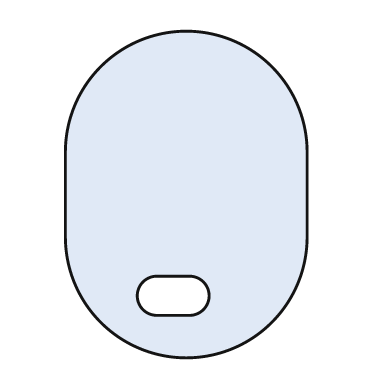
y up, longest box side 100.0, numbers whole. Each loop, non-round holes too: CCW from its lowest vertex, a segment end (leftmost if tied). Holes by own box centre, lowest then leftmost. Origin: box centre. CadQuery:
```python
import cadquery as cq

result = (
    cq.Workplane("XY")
    .moveTo(-37.0, -13.0)
    .threePointArc((0.0, -50.0), (37.0, -13.0))
    .lineTo(37.0, 13.0)
    .threePointArc((0.0, 50.0), (-37.0, 13.0))
    .close()
    .moveTo(-9.0, -37.0)
    .lineTo(1.0, -37.0)
    .threePointArc((7.0, -31.0), (1.0, -25.0))
    .lineTo(-9.0, -25.0)
    .threePointArc((-15.0, -31.0), (-9.0, -37.0))
    .close()
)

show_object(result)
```